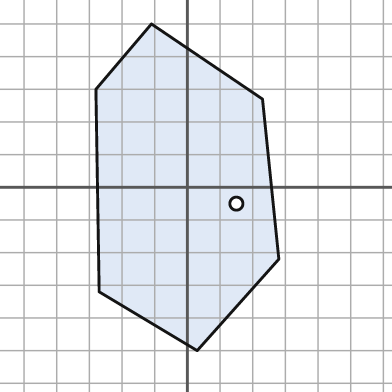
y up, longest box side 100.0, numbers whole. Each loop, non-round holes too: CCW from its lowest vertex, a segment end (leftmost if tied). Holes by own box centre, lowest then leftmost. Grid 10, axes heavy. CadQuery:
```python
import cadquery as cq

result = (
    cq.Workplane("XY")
    .moveTo(3.0, -50.0)
    .lineTo(28.0, -22.0)
    .lineTo(23.0, 27.0)
    .lineTo(-11.0, 50.0)
    .lineTo(-28.0, 30.0)
    .lineTo(-27.0, -32.0)
    .close()
    .moveTo(15.0, -5.0)
    .circle(2.0)
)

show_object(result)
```